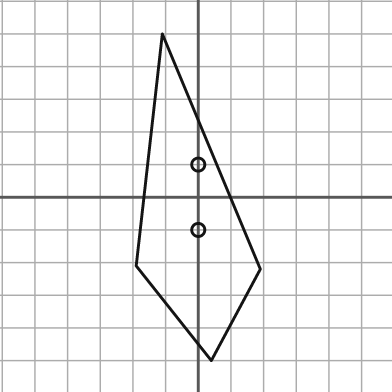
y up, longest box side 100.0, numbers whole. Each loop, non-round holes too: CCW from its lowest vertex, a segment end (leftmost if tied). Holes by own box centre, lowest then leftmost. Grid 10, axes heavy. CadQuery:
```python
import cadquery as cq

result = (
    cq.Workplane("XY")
    .moveTo(4.0, -50.0)
    .lineTo(19.0, -22.0)
    .lineTo(-11.0, 50.0)
    .lineTo(-19.0, -21.0)
    .close()
    .moveTo(0.0, -10.0)
    .circle(2.0)
    .moveTo(0.0, 10.0)
    .circle(2.0)
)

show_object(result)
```